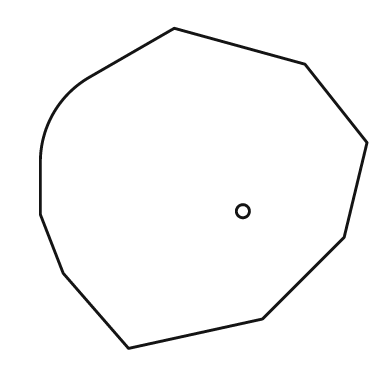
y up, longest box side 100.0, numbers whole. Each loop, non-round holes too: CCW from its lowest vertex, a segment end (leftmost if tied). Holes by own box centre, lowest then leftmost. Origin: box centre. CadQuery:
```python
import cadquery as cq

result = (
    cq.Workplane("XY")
    .moveTo(-23.0, -49.0)
    .lineTo(18.0, -40.0)
    .lineTo(43.0, -15.0)
    .lineTo(50.0, 14.0)
    .lineTo(31.0, 38.0)
    .lineTo(-9.0, 49.0)
    .lineTo(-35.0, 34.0)
    .threePointArc((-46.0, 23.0), (-50.0, 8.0))
    .lineTo(-50.0, -8.0)
    .lineTo(-43.0, -26.0)
    .close()
    .moveTo(12.0, -7.0)
    .circle(2.0)
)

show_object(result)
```